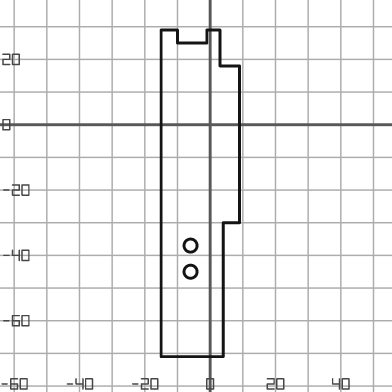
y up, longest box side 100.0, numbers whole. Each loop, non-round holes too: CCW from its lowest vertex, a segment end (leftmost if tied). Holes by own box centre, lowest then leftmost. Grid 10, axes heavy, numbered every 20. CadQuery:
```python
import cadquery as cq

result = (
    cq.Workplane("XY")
    .moveTo(-15.0, -71.0)
    .lineTo(4.0, -71.0)
    .lineTo(4.0, -30.0)
    .lineTo(9.0, -30.0)
    .lineTo(9.0, 18.0)
    .lineTo(3.0, 18.0)
    .lineTo(3.0, 29.0)
    .lineTo(-1.0, 29.0)
    .lineTo(-1.0, 25.0)
    .lineTo(-10.0, 25.0)
    .lineTo(-10.0, 29.0)
    .lineTo(-15.0, 29.0)
    .close()
    .moveTo(-6.0, -45.0)
    .circle(2.0)
    .moveTo(-6.0, -37.0)
    .circle(2.0)
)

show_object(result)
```